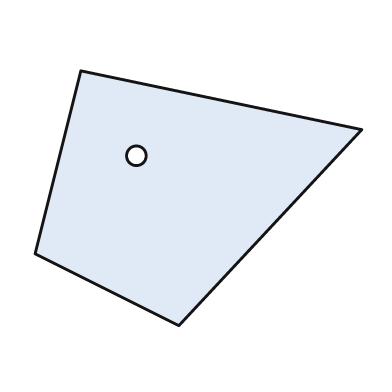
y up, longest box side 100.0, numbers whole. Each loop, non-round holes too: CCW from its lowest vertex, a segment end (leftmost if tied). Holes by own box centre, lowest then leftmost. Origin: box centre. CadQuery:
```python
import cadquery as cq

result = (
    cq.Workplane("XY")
    .moveTo(-6.0, -39.0)
    .lineTo(50.0, 21.0)
    .lineTo(-36.0, 39.0)
    .lineTo(-50.0, -17.0)
    .close()
    .moveTo(-19.0, 13.0)
    .circle(3.0)
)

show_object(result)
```